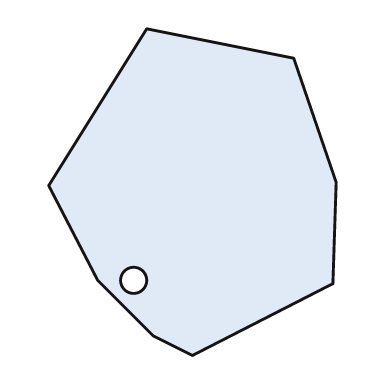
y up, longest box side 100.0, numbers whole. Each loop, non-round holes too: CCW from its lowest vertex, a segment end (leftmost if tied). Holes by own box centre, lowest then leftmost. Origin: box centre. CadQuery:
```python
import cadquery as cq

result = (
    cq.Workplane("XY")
    .moveTo(0.0, -50.0)
    .lineTo(43.0, -28.0)
    .lineTo(44.0, 3.0)
    .lineTo(31.0, 41.0)
    .lineTo(-14.0, 50.0)
    .lineTo(-44.0, 2.0)
    .lineTo(-29.0, -27.0)
    .lineTo(-12.0, -44.0)
    .close()
    .moveTo(-18.0, -27.0)
    .circle(4.0)
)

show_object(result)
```